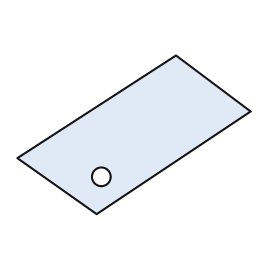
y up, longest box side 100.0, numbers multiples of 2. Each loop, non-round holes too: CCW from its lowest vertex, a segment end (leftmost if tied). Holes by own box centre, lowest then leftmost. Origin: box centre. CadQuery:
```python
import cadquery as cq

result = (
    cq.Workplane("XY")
    .moveTo(-16.0, -34.0)
    .lineTo(50.0, 10.0)
    .lineTo(18.0, 34.0)
    .lineTo(-50.0, -10.0)
    .close()
    .moveTo(-14.0, -18.0)
    .circle(4.0)
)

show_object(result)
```